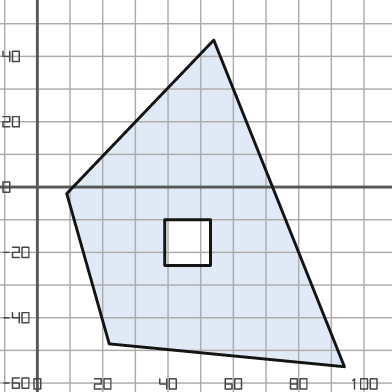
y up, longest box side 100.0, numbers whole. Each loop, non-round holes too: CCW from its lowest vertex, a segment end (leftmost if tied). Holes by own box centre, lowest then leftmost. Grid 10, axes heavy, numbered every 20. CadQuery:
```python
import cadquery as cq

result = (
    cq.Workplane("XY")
    .moveTo(94.0, -55.0)
    .lineTo(54.0, 45.0)
    .lineTo(9.0, -2.0)
    .lineTo(22.0, -48.0)
    .close()
    .moveTo(39.0, -24.0)
    .lineTo(53.0, -24.0)
    .lineTo(53.0, -10.0)
    .lineTo(39.0, -10.0)
    .close()
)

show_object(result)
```